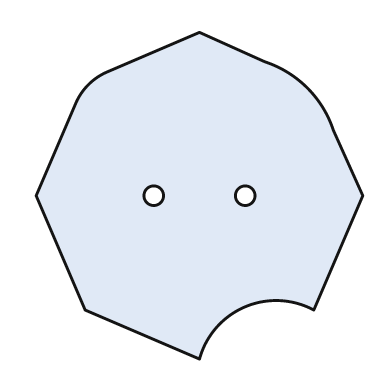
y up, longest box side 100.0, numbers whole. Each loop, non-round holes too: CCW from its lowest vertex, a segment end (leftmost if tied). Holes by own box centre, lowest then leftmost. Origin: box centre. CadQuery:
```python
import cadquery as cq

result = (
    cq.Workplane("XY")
    .moveTo(0.0, -50.0)
    .threePointArc((14.0, -34.0), (35.0, -35.0))
    .lineTo(50.0, 0.0)
    .lineTo(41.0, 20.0)
    .threePointArc((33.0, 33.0), (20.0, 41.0))
    .lineTo(0.0, 50.0)
    .lineTo(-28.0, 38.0)
    .threePointArc((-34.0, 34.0), (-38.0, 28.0))
    .lineTo(-50.0, 0.0)
    .lineTo(-35.0, -35.0)
    .close()
    .moveTo(-14.0, 0.0)
    .circle(3.0)
    .moveTo(14.0, 0.0)
    .circle(3.0)
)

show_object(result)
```